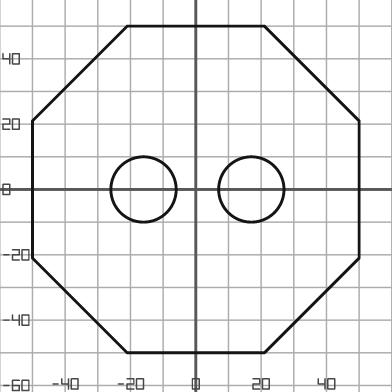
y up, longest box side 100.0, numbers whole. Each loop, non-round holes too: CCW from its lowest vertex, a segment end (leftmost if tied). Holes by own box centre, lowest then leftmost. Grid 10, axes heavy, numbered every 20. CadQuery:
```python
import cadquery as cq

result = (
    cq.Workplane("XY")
    .moveTo(-21.0, -50.0)
    .lineTo(21.0, -50.0)
    .lineTo(50.0, -21.0)
    .lineTo(50.0, 21.0)
    .lineTo(21.0, 50.0)
    .lineTo(-21.0, 50.0)
    .lineTo(-50.0, 21.0)
    .lineTo(-50.0, -21.0)
    .close()
    .moveTo(-16.0, 0.0)
    .circle(10.0)
    .moveTo(17.0, 0.0)
    .circle(10.0)
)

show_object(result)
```